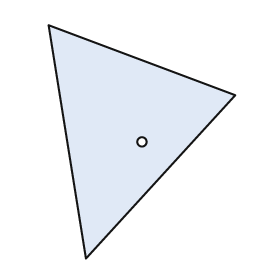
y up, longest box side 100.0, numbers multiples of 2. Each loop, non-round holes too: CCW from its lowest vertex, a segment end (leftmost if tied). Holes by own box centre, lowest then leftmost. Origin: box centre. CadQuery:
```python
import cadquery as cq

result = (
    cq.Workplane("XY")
    .moveTo(-24.0, -50.0)
    .lineTo(40.0, 20.0)
    .lineTo(-40.0, 50.0)
    .close()
    .moveTo(0.0, 0.0)
    .circle(2.0)
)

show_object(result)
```